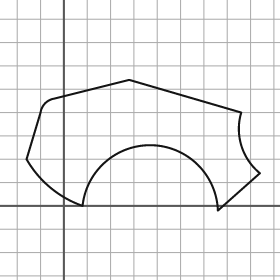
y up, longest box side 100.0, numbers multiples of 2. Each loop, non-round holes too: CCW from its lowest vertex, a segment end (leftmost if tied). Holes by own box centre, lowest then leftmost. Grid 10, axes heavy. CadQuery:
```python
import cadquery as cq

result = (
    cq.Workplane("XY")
    .moveTo(66.0, -2.0)
    .lineTo(84.0, 14.0)
    .threePointArc((76.0, 26.0), (76.0, 40.0))
    .lineTo(28.0, 54.0)
    .lineTo(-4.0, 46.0)
    .threePointArc((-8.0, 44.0), (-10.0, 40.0))
    .lineTo(-16.0, 20.0)
    .threePointArc((-6.0, 8.0), (8.0, 0.0))
    .threePointArc((38.0, 26.0), (66.0, -2.0))
    .close()
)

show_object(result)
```